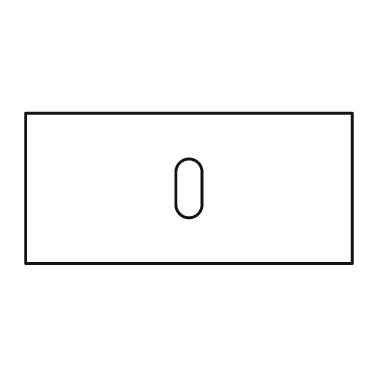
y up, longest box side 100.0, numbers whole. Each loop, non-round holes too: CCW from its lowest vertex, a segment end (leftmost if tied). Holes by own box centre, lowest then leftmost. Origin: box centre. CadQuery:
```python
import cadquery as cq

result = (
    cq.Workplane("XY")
    .moveTo(-50.0, -23.0)
    .lineTo(50.0, -23.0)
    .lineTo(50.0, 23.0)
    .lineTo(-50.0, 23.0)
    .close()
    .moveTo(-4.0, -5.0)
    .threePointArc((0.0, -9.0), (4.0, -5.0))
    .lineTo(4.0, 5.0)
    .threePointArc((0.0, 9.0), (-4.0, 5.0))
    .close()
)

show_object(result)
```